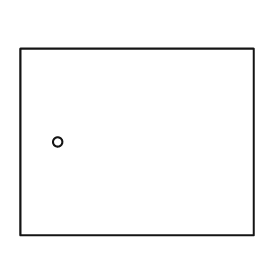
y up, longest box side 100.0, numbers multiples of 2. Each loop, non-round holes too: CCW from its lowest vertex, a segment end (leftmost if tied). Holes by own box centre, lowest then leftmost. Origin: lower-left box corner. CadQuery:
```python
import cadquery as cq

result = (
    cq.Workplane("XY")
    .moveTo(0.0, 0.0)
    .lineTo(100.0, 0.0)
    .lineTo(100.0, 80.0)
    .lineTo(0.0, 80.0)
    .close()
    .moveTo(16.0, 40.0)
    .circle(2.0)
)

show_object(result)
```